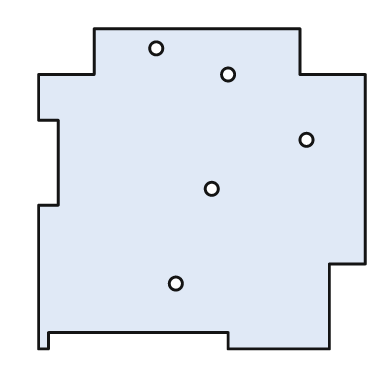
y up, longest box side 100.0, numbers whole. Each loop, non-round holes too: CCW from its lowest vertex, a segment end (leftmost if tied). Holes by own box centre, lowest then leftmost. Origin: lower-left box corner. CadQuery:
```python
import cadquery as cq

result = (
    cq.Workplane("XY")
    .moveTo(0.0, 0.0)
    .lineTo(3.0, 0.0)
    .lineTo(3.0, 5.0)
    .lineTo(58.0, 5.0)
    .lineTo(58.0, 0.0)
    .lineTo(89.0, 0.0)
    .lineTo(89.0, 26.0)
    .lineTo(100.0, 26.0)
    .lineTo(100.0, 84.0)
    .lineTo(80.0, 84.0)
    .lineTo(80.0, 98.0)
    .lineTo(17.0, 98.0)
    .lineTo(17.0, 84.0)
    .lineTo(0.0, 84.0)
    .lineTo(0.0, 70.0)
    .lineTo(6.0, 70.0)
    .lineTo(6.0, 44.0)
    .lineTo(0.0, 44.0)
    .close()
    .moveTo(42.0, 20.0)
    .circle(2.0)
    .moveTo(53.0, 49.0)
    .circle(2.0)
    .moveTo(82.0, 64.0)
    .circle(2.0)
    .moveTo(58.0, 84.0)
    .circle(2.0)
    .moveTo(36.0, 92.0)
    .circle(2.0)
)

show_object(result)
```